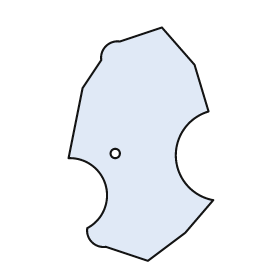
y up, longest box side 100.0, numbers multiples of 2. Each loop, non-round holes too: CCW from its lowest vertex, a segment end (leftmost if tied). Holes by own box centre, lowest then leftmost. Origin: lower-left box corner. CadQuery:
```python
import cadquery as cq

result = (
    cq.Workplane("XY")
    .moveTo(34.0, 0.0)
    .lineTo(50.0, 12.0)
    .lineTo(62.0, 26.0)
    .threePointArc((46.0, 44.0), (60.0, 64.0))
    .lineTo(54.0, 84.0)
    .lineTo(40.0, 100.0)
    .lineTo(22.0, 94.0)
    .threePointArc((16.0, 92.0), (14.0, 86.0))
    .lineTo(6.0, 74.0)
    .lineTo(0.0, 44.0)
    .threePointArc((16.0, 32.0), (8.0, 14.0))
    .threePointArc((10.0, 8.0), (16.0, 6.0))
    .close()
    .moveTo(20.0, 46.0)
    .circle(2.0)
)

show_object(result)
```